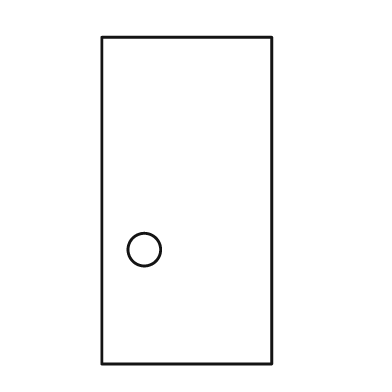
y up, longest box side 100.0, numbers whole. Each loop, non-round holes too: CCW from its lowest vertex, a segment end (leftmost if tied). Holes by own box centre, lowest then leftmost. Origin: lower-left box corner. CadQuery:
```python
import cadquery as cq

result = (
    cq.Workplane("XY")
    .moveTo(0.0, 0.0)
    .lineTo(52.0, 0.0)
    .lineTo(52.0, 100.0)
    .lineTo(0.0, 100.0)
    .close()
    .moveTo(13.0, 35.0)
    .circle(5.0)
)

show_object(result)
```